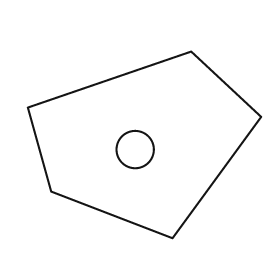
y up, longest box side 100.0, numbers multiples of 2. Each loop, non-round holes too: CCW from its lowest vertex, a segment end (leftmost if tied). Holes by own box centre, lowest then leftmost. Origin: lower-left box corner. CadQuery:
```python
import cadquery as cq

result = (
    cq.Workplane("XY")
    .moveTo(62.0, 0.0)
    .lineTo(100.0, 52.0)
    .lineTo(70.0, 80.0)
    .lineTo(0.0, 56.0)
    .lineTo(10.0, 20.0)
    .close()
    .moveTo(46.0, 38.0)
    .circle(8.0)
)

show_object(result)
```